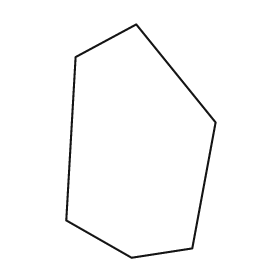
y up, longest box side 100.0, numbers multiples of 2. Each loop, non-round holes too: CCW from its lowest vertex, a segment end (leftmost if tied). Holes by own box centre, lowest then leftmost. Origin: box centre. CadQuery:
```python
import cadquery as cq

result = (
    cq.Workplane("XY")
    .moveTo(-4.0, -50.0)
    .lineTo(22.0, -46.0)
    .lineTo(32.0, 8.0)
    .lineTo(-2.0, 50.0)
    .lineTo(-28.0, 36.0)
    .lineTo(-32.0, -34.0)
    .close()
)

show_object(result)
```